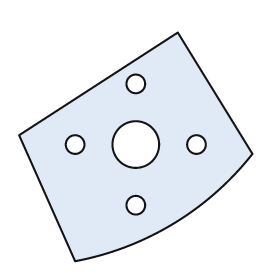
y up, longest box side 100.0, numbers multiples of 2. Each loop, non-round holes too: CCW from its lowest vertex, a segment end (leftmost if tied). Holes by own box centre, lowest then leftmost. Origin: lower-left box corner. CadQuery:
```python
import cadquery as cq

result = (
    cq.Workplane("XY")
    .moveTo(24.0, 0.0)
    .threePointArc((66.0, 16.0), (100.0, 46.0))
    .lineTo(68.0, 98.0)
    .lineTo(0.0, 54.0)
    .close()
    .moveTo(50.0, 24.0)
    .circle(4.0)
    .moveTo(24.0, 50.0)
    .circle(4.0)
    .moveTo(50.0, 50.0)
    .circle(10.0)
    .moveTo(76.0, 50.0)
    .circle(4.0)
    .moveTo(50.0, 76.0)
    .circle(4.0)
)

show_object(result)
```